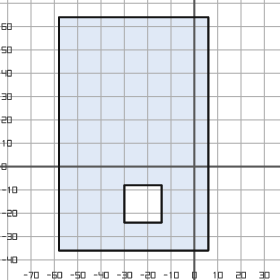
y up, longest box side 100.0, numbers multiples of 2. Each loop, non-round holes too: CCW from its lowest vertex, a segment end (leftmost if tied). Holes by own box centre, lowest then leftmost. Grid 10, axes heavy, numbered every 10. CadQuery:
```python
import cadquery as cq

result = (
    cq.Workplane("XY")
    .moveTo(-58.0, -36.0)
    .lineTo(6.0, -36.0)
    .lineTo(6.0, 64.0)
    .lineTo(-58.0, 64.0)
    .close()
    .moveTo(-30.0, -24.0)
    .lineTo(-14.0, -24.0)
    .lineTo(-14.0, -8.0)
    .lineTo(-30.0, -8.0)
    .close()
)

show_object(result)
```